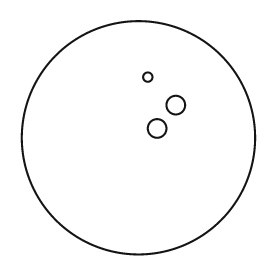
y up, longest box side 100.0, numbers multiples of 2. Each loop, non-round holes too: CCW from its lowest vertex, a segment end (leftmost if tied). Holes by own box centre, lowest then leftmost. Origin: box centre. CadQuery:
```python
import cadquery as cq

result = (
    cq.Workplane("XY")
    .moveTo(0.0, 0.0)
    .circle(50.0)
    .moveTo(8.0, 4.0)
    .circle(4.0)
    .moveTo(16.0, 14.0)
    .circle(4.0)
    .moveTo(4.0, 26.0)
    .circle(2.0)
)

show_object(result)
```